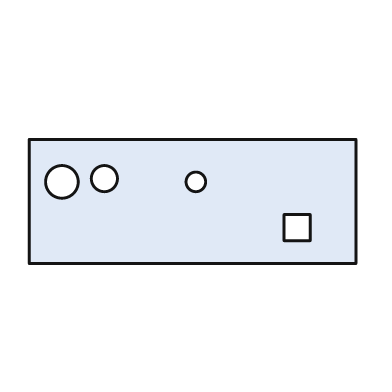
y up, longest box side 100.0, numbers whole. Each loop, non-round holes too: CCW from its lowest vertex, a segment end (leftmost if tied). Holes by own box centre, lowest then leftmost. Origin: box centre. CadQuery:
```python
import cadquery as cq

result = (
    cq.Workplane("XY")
    .moveTo(-50.0, -19.0)
    .lineTo(50.0, -19.0)
    .lineTo(50.0, 19.0)
    .lineTo(-50.0, 19.0)
    .close()
    .moveTo(28.0, -12.0)
    .lineTo(36.0, -12.0)
    .lineTo(36.0, -4.0)
    .lineTo(28.0, -4.0)
    .close()
    .moveTo(-40.0, 6.0)
    .circle(5.0)
    .moveTo(1.0, 6.0)
    .circle(3.0)
    .moveTo(-27.0, 7.0)
    .circle(4.0)
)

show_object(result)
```